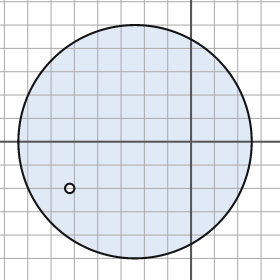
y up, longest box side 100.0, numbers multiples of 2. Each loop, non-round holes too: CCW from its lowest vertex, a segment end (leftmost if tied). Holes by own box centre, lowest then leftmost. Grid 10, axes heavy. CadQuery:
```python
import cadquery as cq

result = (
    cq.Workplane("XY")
    .moveTo(-24.0, 0.0)
    .circle(50.0)
    .moveTo(-52.0, -20.0)
    .circle(2.0)
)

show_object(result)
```